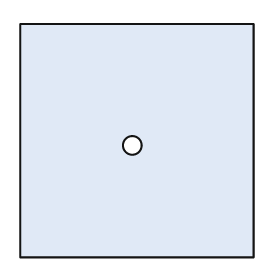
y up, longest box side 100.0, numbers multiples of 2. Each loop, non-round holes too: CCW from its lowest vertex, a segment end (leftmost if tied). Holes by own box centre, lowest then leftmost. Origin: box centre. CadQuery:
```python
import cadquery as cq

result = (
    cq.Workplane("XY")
    .moveTo(-50.0, -50.0)
    .lineTo(50.0, -50.0)
    .lineTo(50.0, 50.0)
    .lineTo(-50.0, 50.0)
    .close()
    .moveTo(-2.0, -2.0)
    .circle(4.0)
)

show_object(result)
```